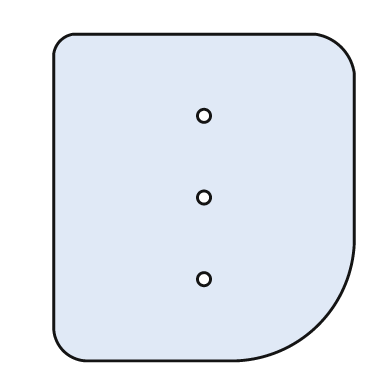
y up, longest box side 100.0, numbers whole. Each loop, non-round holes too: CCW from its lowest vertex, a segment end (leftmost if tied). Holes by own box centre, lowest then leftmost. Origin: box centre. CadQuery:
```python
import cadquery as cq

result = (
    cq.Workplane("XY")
    .moveTo(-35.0, -50.0)
    .lineTo(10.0, -50.0)
    .threePointArc((35.0, -39.0), (46.0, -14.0))
    .lineTo(46.0, 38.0)
    .threePointArc((42.0, 46.0), (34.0, 50.0))
    .lineTo(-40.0, 50.0)
    .threePointArc((-44.0, 48.0), (-46.0, 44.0))
    .lineTo(-46.0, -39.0)
    .threePointArc((-43.0, -47.0), (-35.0, -50.0))
    .close()
    .moveTo(0.0, -25.0)
    .circle(2.0)
    .moveTo(0.0, 0.0)
    .circle(2.0)
    .moveTo(0.0, 25.0)
    .circle(2.0)
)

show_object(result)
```